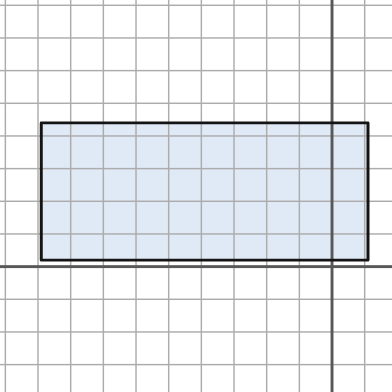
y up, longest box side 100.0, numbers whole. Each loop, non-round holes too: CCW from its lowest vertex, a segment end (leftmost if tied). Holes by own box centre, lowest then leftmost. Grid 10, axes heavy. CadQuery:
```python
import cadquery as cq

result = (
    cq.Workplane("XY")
    .moveTo(-89.0, 2.0)
    .lineTo(11.0, 2.0)
    .lineTo(11.0, 44.0)
    .lineTo(-89.0, 44.0)
    .close()
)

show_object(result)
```